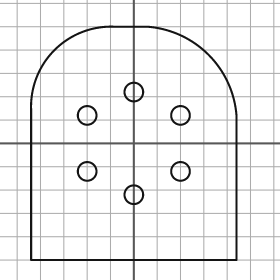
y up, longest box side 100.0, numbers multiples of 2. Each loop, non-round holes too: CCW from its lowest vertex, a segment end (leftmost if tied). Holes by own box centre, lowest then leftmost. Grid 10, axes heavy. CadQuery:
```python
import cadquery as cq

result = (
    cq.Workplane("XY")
    .moveTo(-44.0, -50.0)
    .lineTo(44.0, -50.0)
    .lineTo(44.0, 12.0)
    .threePointArc((32.0, 38.0), (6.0, 50.0))
    .lineTo(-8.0, 50.0)
    .threePointArc((-34.0, 40.0), (-44.0, 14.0))
    .close()
    .moveTo(0.0, -22.0)
    .circle(4.0)
    .moveTo(-20.0, -12.0)
    .circle(4.0)
    .moveTo(20.0, -12.0)
    .circle(4.0)
    .moveTo(-20.0, 12.0)
    .circle(4.0)
    .moveTo(20.0, 12.0)
    .circle(4.0)
    .moveTo(0.0, 22.0)
    .circle(4.0)
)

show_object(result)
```